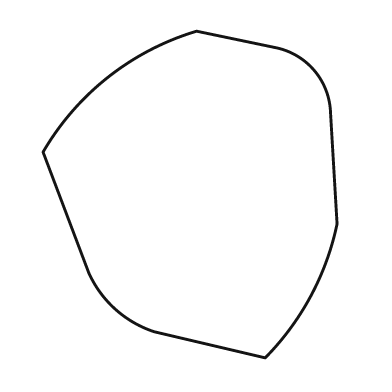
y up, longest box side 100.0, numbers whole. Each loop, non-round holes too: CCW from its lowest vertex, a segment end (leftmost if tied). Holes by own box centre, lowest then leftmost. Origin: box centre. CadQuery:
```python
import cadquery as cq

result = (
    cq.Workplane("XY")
    .moveTo(23.0, -50.0)
    .threePointArc((37.0, -31.0), (45.0, -9.0))
    .lineTo(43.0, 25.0)
    .threePointArc((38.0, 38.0), (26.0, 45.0))
    .lineTo(2.0, 50.0)
    .threePointArc((-25.0, 36.0), (-45.0, 13.0))
    .lineTo(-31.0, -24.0)
    .threePointArc((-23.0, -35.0), (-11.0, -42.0))
    .close()
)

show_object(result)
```